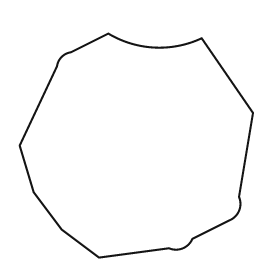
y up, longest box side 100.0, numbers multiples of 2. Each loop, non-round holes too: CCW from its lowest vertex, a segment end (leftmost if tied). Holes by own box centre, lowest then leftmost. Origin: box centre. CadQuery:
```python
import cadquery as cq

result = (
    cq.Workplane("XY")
    .moveTo(-16.0, -48.0)
    .lineTo(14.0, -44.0)
    .threePointArc((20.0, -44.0), (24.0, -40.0))
    .lineTo(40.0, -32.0)
    .threePointArc((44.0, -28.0), (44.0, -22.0))
    .lineTo(50.0, 14.0)
    .lineTo(28.0, 46.0)
    .threePointArc((8.0, 42.0), (-12.0, 48.0))
    .lineTo(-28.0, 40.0)
    .threePointArc((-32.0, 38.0), (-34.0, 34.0))
    .lineTo(-50.0, 0.0)
    .lineTo(-44.0, -20.0)
    .lineTo(-32.0, -36.0)
    .close()
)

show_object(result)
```